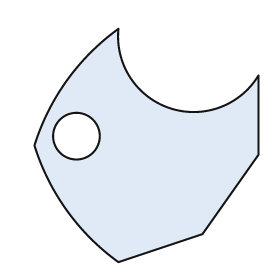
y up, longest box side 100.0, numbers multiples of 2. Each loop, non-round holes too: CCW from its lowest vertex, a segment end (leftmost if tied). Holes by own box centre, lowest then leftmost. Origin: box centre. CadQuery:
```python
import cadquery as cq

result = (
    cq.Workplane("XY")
    .moveTo(-12.0, -50.0)
    .lineTo(24.0, -38.0)
    .lineTo(48.0, -4.0)
    .lineTo(48.0, 30.0)
    .threePointArc((10.0, 16.0), (-12.0, 50.0))
    .threePointArc((-34.0, 28.0), (-48.0, 0.0))
    .threePointArc((-34.0, -28.0), (-12.0, -50.0))
    .close()
    .moveTo(-30.0, 4.0)
    .circle(10.0)
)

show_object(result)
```